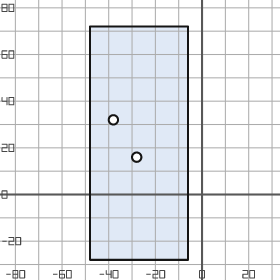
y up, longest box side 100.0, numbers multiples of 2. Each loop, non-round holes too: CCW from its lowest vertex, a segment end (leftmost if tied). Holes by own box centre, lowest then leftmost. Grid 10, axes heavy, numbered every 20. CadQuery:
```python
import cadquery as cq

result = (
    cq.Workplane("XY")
    .moveTo(-48.0, -28.0)
    .lineTo(-6.0, -28.0)
    .lineTo(-6.0, 72.0)
    .lineTo(-48.0, 72.0)
    .close()
    .moveTo(-28.0, 16.0)
    .circle(2.0)
    .moveTo(-38.0, 32.0)
    .circle(2.0)
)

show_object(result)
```